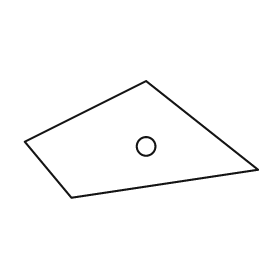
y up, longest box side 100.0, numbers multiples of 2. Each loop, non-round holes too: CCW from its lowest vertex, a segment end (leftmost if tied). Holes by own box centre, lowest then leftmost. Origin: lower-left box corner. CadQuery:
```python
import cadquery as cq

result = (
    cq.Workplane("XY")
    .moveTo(20.0, 0.0)
    .lineTo(100.0, 12.0)
    .lineTo(52.0, 50.0)
    .lineTo(0.0, 24.0)
    .close()
    .moveTo(52.0, 22.0)
    .circle(4.0)
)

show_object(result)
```